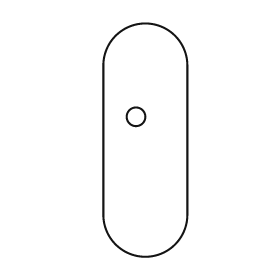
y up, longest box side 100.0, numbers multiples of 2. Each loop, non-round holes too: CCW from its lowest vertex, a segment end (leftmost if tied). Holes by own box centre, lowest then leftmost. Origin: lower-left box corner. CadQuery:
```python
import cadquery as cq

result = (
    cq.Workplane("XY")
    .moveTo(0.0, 18.0)
    .threePointArc((18.0, 0.0), (36.0, 18.0))
    .lineTo(36.0, 82.0)
    .threePointArc((18.0, 100.0), (0.0, 82.0))
    .close()
    .moveTo(14.0, 60.0)
    .circle(4.0)
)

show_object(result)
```